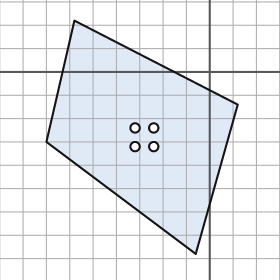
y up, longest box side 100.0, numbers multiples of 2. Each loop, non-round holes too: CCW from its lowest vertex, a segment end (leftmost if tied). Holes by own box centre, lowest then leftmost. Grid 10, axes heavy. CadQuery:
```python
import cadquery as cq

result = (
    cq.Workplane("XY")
    .moveTo(-6.0, -78.0)
    .lineTo(12.0, -14.0)
    .lineTo(-58.0, 22.0)
    .lineTo(-70.0, -30.0)
    .close()
    .moveTo(-32.0, -32.0)
    .circle(2.0)
    .moveTo(-24.0, -32.0)
    .circle(2.0)
    .moveTo(-32.0, -24.0)
    .circle(2.0)
    .moveTo(-24.0, -24.0)
    .circle(2.0)
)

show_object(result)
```